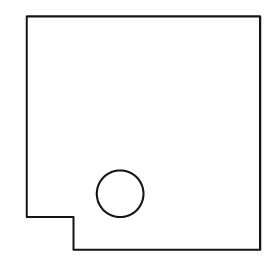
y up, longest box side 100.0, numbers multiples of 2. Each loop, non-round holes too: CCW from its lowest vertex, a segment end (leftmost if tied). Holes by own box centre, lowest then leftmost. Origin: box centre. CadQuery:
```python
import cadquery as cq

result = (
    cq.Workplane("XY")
    .moveTo(-30.0, -50.0)
    .lineTo(50.0, -50.0)
    .lineTo(50.0, 50.0)
    .lineTo(-50.0, 50.0)
    .lineTo(-50.0, -36.0)
    .lineTo(-30.0, -36.0)
    .close()
    .moveTo(-10.0, -26.0)
    .circle(10.0)
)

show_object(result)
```